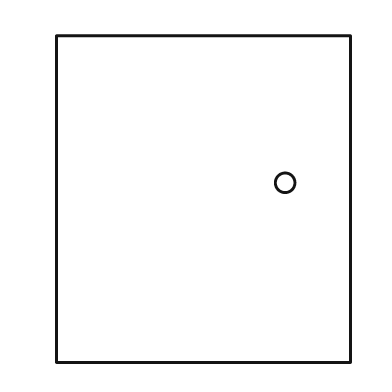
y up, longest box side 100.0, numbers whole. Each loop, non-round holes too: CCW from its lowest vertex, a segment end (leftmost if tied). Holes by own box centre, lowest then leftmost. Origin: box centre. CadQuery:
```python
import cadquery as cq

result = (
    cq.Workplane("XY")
    .moveTo(-45.0, -50.0)
    .lineTo(45.0, -50.0)
    .lineTo(45.0, 50.0)
    .lineTo(-45.0, 50.0)
    .close()
    .moveTo(25.0, 5.0)
    .circle(3.0)
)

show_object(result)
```